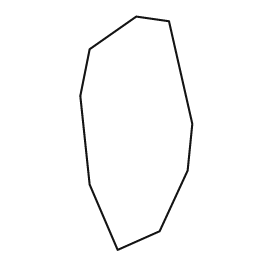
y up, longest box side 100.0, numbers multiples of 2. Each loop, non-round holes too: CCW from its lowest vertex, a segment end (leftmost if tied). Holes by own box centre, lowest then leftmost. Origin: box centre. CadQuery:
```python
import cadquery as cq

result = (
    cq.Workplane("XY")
    .moveTo(-8.0, -50.0)
    .lineTo(10.0, -42.0)
    .lineTo(22.0, -16.0)
    .lineTo(24.0, 4.0)
    .lineTo(14.0, 48.0)
    .lineTo(0.0, 50.0)
    .lineTo(-20.0, 36.0)
    .lineTo(-24.0, 16.0)
    .lineTo(-20.0, -22.0)
    .close()
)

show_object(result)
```